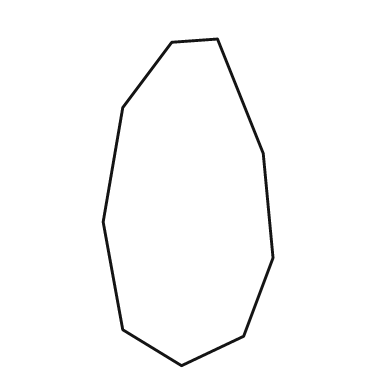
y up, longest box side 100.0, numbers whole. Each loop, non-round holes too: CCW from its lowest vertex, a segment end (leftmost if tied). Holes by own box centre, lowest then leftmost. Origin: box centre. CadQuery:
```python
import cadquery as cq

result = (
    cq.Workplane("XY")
    .moveTo(-2.0, -50.0)
    .lineTo(17.0, -41.0)
    .lineTo(26.0, -17.0)
    .lineTo(23.0, 15.0)
    .lineTo(9.0, 50.0)
    .lineTo(-5.0, 49.0)
    .lineTo(-20.0, 29.0)
    .lineTo(-26.0, -6.0)
    .lineTo(-20.0, -39.0)
    .close()
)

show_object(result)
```